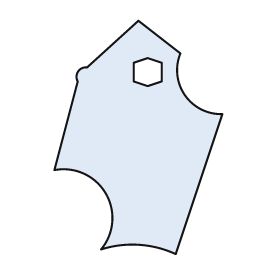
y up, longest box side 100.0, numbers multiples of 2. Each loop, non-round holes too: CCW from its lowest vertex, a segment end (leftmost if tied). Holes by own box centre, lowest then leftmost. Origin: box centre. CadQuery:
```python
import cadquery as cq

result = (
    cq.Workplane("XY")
    .moveTo(16.0, -50.0)
    .lineTo(36.0, 10.0)
    .threePointArc((20.0, 18.0), (18.0, 36.0))
    .lineTo(0.0, 50.0)
    .lineTo(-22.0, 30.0)
    .threePointArc((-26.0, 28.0), (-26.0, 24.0))
    .lineTo(-36.0, -14.0)
    .threePointArc((-14.0, -24.0), (-16.0, -48.0))
    .threePointArc((0.0, -46.0), (16.0, -50.0))
    .close()
    .moveTo(4.0, 22.0)
    .lineTo(10.0, 24.0)
    .lineTo(10.0, 32.0)
    .lineTo(4.0, 34.0)
    .lineTo(-2.0, 32.0)
    .lineTo(-2.0, 24.0)
    .close()
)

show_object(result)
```